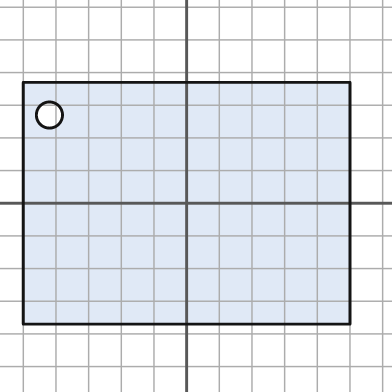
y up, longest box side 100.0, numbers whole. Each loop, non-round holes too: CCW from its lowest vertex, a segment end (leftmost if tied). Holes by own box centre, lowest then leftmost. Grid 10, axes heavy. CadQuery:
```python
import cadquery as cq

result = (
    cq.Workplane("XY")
    .moveTo(-50.0, -37.0)
    .lineTo(50.0, -37.0)
    .lineTo(50.0, 37.0)
    .lineTo(-50.0, 37.0)
    .close()
    .moveTo(-42.0, 27.0)
    .circle(4.0)
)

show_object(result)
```